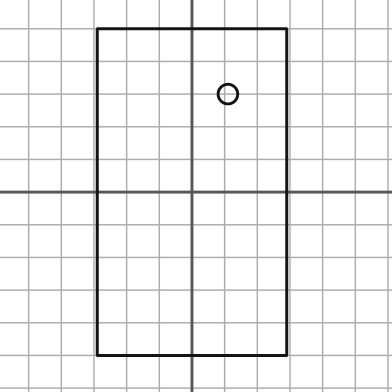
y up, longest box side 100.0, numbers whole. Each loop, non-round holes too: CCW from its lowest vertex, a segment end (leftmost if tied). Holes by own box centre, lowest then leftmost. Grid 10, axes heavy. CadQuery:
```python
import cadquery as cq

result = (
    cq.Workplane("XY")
    .moveTo(-29.0, -50.0)
    .lineTo(29.0, -50.0)
    .lineTo(29.0, 50.0)
    .lineTo(-29.0, 50.0)
    .close()
    .moveTo(11.0, 30.0)
    .circle(3.0)
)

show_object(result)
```